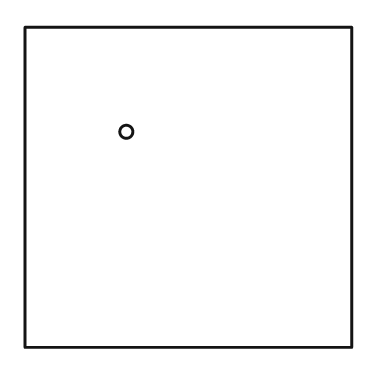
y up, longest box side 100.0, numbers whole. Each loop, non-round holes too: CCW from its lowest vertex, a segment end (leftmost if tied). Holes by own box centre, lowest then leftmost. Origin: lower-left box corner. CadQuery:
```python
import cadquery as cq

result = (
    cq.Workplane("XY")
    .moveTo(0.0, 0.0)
    .lineTo(100.0, 0.0)
    .lineTo(100.0, 98.0)
    .lineTo(0.0, 98.0)
    .close()
    .moveTo(31.0, 66.0)
    .circle(2.0)
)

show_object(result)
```